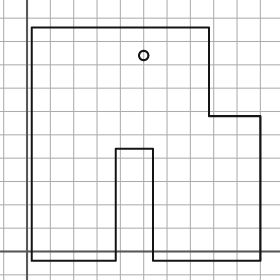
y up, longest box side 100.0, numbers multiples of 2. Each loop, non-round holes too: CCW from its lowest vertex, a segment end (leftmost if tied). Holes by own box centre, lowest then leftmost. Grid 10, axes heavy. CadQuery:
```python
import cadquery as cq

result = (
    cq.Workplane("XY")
    .moveTo(2.0, -4.0)
    .lineTo(38.0, -4.0)
    .lineTo(38.0, 44.0)
    .lineTo(54.0, 44.0)
    .lineTo(54.0, -4.0)
    .lineTo(100.0, -4.0)
    .lineTo(100.0, 58.0)
    .lineTo(78.0, 58.0)
    .lineTo(78.0, 96.0)
    .lineTo(2.0, 96.0)
    .close()
    .moveTo(50.0, 84.0)
    .circle(2.0)
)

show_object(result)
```